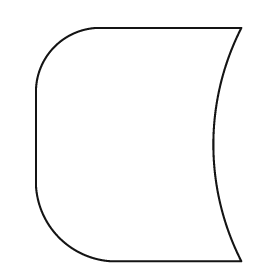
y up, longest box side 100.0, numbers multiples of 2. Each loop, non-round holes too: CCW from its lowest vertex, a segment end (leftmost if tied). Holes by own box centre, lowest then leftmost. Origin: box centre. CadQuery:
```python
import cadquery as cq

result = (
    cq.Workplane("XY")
    .moveTo(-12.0, -50.0)
    .lineTo(44.0, -50.0)
    .threePointArc((32.0, 0.0), (44.0, 50.0))
    .lineTo(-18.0, 50.0)
    .threePointArc((-36.0, 42.0), (-44.0, 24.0))
    .lineTo(-44.0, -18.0)
    .threePointArc((-34.0, -40.0), (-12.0, -50.0))
    .close()
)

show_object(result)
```